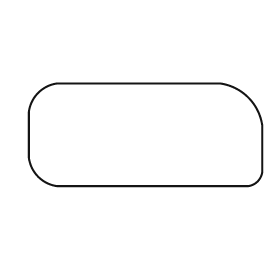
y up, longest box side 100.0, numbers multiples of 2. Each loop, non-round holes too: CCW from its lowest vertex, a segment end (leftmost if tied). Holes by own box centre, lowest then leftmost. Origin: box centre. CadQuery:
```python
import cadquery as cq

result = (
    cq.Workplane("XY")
    .moveTo(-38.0, -22.0)
    .lineTo(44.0, -22.0)
    .threePointArc((48.0, -20.0), (50.0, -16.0))
    .lineTo(50.0, 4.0)
    .threePointArc((44.0, 16.0), (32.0, 22.0))
    .lineTo(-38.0, 22.0)
    .threePointArc((-46.0, 18.0), (-50.0, 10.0))
    .lineTo(-50.0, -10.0)
    .threePointArc((-46.0, -18.0), (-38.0, -22.0))
    .close()
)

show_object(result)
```